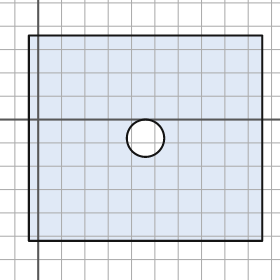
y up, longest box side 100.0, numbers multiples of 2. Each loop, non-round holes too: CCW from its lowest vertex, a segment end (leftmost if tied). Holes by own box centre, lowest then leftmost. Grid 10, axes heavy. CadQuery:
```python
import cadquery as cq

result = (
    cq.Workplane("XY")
    .moveTo(-4.0, -52.0)
    .lineTo(96.0, -52.0)
    .lineTo(96.0, 36.0)
    .lineTo(-4.0, 36.0)
    .close()
    .moveTo(46.0, -8.0)
    .circle(8.0)
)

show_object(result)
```